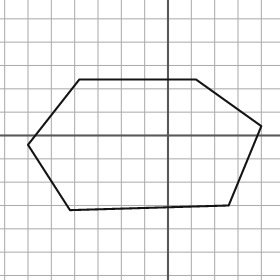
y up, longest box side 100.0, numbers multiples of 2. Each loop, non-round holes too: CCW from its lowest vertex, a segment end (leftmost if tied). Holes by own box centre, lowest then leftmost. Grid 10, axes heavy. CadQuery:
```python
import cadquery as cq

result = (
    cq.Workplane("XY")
    .moveTo(-42.0, -32.0)
    .lineTo(26.0, -30.0)
    .lineTo(40.0, 4.0)
    .lineTo(12.0, 24.0)
    .lineTo(-38.0, 24.0)
    .lineTo(-60.0, -4.0)
    .close()
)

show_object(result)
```